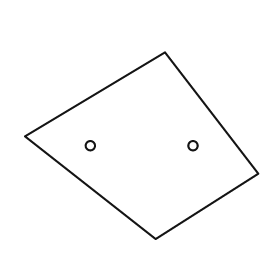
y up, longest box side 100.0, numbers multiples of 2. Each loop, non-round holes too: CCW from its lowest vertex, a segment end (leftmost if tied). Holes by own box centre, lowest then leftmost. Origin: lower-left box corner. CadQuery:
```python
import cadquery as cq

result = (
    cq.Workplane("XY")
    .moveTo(56.0, 0.0)
    .lineTo(100.0, 28.0)
    .lineTo(60.0, 80.0)
    .lineTo(0.0, 44.0)
    .close()
    .moveTo(28.0, 40.0)
    .circle(2.0)
    .moveTo(72.0, 40.0)
    .circle(2.0)
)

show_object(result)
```